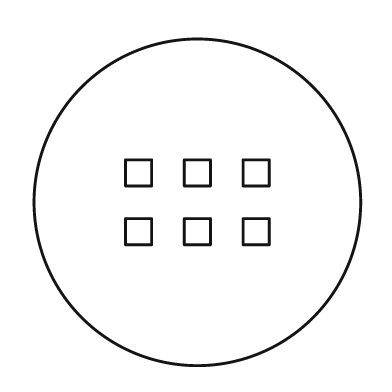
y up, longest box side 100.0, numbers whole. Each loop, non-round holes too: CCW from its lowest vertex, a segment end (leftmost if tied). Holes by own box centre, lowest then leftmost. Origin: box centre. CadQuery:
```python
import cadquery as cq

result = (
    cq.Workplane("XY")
    .moveTo(0.0, 0.0)
    .circle(50.0)
    .moveTo(-22.0, -13.0)
    .lineTo(-14.0, -13.0)
    .lineTo(-14.0, -5.0)
    .lineTo(-22.0, -5.0)
    .close()
    .moveTo(-4.0, -13.0)
    .lineTo(4.0, -13.0)
    .lineTo(4.0, -5.0)
    .lineTo(-4.0, -5.0)
    .close()
    .moveTo(14.0, -13.0)
    .lineTo(22.0, -13.0)
    .lineTo(22.0, -5.0)
    .lineTo(14.0, -5.0)
    .close()
    .moveTo(-22.0, 5.0)
    .lineTo(-14.0, 5.0)
    .lineTo(-14.0, 13.0)
    .lineTo(-22.0, 13.0)
    .close()
    .moveTo(-4.0, 5.0)
    .lineTo(4.0, 5.0)
    .lineTo(4.0, 13.0)
    .lineTo(-4.0, 13.0)
    .close()
    .moveTo(14.0, 5.0)
    .lineTo(22.0, 5.0)
    .lineTo(22.0, 13.0)
    .lineTo(14.0, 13.0)
    .close()
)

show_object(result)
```